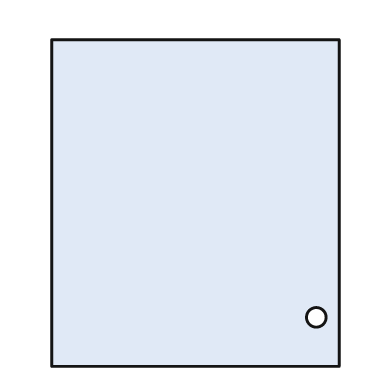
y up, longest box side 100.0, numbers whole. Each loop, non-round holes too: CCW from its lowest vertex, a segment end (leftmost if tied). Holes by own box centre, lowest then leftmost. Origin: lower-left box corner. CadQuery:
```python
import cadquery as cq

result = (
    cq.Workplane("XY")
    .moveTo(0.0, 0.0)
    .lineTo(88.0, 0.0)
    .lineTo(88.0, 100.0)
    .lineTo(0.0, 100.0)
    .close()
    .moveTo(81.0, 15.0)
    .circle(3.0)
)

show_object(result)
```